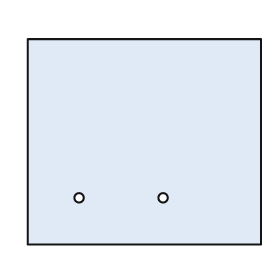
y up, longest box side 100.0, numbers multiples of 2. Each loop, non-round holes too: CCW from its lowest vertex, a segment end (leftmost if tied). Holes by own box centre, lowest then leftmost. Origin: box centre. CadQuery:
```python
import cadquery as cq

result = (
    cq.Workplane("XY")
    .moveTo(-50.0, -44.0)
    .lineTo(50.0, -44.0)
    .lineTo(50.0, 44.0)
    .lineTo(-50.0, 44.0)
    .close()
    .moveTo(-28.0, -24.0)
    .circle(2.0)
    .moveTo(8.0, -24.0)
    .circle(2.0)
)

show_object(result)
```